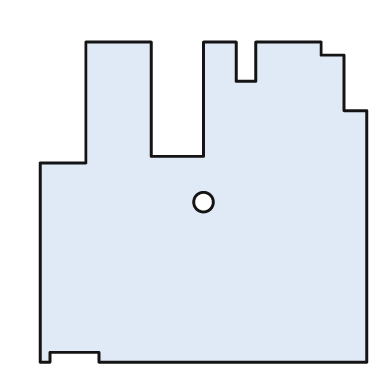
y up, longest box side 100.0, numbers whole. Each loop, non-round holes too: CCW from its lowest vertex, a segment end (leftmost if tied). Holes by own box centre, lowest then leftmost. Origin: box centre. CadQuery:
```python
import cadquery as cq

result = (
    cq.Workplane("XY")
    .moveTo(-50.0, -49.0)
    .lineTo(-47.0, -49.0)
    .lineTo(-47.0, -46.0)
    .lineTo(-32.0, -46.0)
    .lineTo(-32.0, -49.0)
    .lineTo(50.0, -49.0)
    .lineTo(50.0, 28.0)
    .lineTo(43.0, 28.0)
    .lineTo(43.0, 45.0)
    .lineTo(36.0, 45.0)
    .lineTo(36.0, 49.0)
    .lineTo(16.0, 49.0)
    .lineTo(16.0, 37.0)
    .lineTo(10.0, 37.0)
    .lineTo(10.0, 49.0)
    .lineTo(0.0, 49.0)
    .lineTo(0.0, 14.0)
    .lineTo(-16.0, 14.0)
    .lineTo(-16.0, 49.0)
    .lineTo(-36.0, 49.0)
    .lineTo(-36.0, 12.0)
    .lineTo(-50.0, 12.0)
    .close()
    .moveTo(0.0, 0.0)
    .circle(3.0)
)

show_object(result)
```